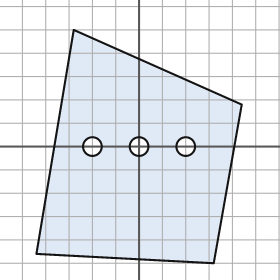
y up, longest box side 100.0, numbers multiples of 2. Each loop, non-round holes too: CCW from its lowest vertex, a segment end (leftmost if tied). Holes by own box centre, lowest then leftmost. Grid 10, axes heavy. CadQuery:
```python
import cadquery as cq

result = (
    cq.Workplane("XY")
    .moveTo(32.0, -50.0)
    .lineTo(44.0, 18.0)
    .lineTo(-28.0, 50.0)
    .lineTo(-44.0, -46.0)
    .close()
    .moveTo(-20.0, 0.0)
    .circle(4.0)
    .moveTo(0.0, 0.0)
    .circle(4.0)
    .moveTo(20.0, 0.0)
    .circle(4.0)
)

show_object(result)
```